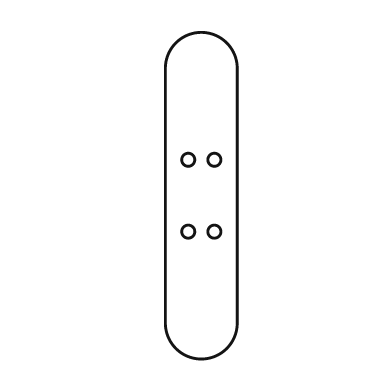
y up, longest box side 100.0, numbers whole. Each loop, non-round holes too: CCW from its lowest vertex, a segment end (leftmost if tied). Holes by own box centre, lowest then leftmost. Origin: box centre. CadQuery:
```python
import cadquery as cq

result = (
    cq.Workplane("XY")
    .moveTo(-11.0, -39.0)
    .threePointArc((0.0, -50.0), (11.0, -39.0))
    .lineTo(11.0, 39.0)
    .threePointArc((0.0, 50.0), (-11.0, 39.0))
    .close()
    .moveTo(-4.0, -11.0)
    .circle(2.0)
    .moveTo(4.0, -11.0)
    .circle(2.0)
    .moveTo(-4.0, 11.0)
    .circle(2.0)
    .moveTo(4.0, 11.0)
    .circle(2.0)
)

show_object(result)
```